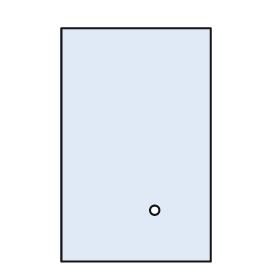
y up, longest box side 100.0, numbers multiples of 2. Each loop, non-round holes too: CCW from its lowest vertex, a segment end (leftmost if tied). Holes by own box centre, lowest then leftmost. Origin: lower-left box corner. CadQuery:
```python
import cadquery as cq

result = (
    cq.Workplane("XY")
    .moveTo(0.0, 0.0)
    .lineTo(64.0, 0.0)
    .lineTo(64.0, 100.0)
    .lineTo(0.0, 100.0)
    .close()
    .moveTo(40.0, 22.0)
    .circle(2.0)
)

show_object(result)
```